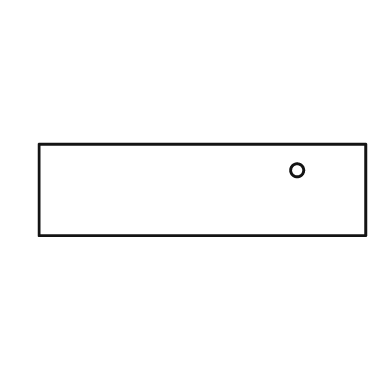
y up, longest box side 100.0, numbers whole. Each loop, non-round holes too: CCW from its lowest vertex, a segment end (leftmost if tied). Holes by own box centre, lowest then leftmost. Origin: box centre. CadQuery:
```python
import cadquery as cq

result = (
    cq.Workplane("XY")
    .moveTo(-50.0, -14.0)
    .lineTo(50.0, -14.0)
    .lineTo(50.0, 14.0)
    .lineTo(-50.0, 14.0)
    .close()
    .moveTo(29.0, 6.0)
    .circle(2.0)
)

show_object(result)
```